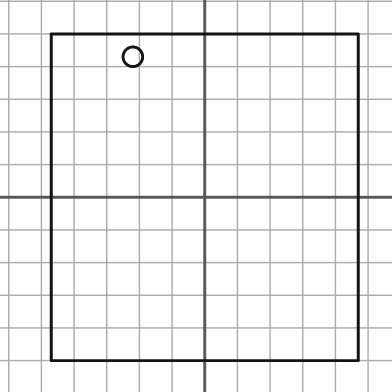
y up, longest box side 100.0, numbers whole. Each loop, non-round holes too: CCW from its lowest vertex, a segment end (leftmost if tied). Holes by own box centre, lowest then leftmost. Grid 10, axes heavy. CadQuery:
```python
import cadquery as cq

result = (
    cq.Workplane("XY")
    .moveTo(-47.0, -50.0)
    .lineTo(47.0, -50.0)
    .lineTo(47.0, 50.0)
    .lineTo(-47.0, 50.0)
    .close()
    .moveTo(-22.0, 43.0)
    .circle(3.0)
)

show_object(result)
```